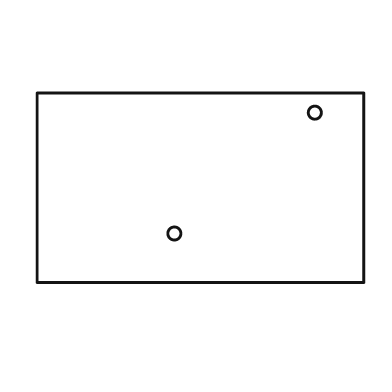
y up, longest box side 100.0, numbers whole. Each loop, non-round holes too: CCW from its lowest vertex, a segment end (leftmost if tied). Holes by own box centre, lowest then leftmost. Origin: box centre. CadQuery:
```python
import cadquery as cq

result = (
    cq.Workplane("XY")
    .moveTo(-50.0, -29.0)
    .lineTo(50.0, -29.0)
    .lineTo(50.0, 29.0)
    .lineTo(-50.0, 29.0)
    .close()
    .moveTo(-8.0, -14.0)
    .circle(2.0)
    .moveTo(35.0, 23.0)
    .circle(2.0)
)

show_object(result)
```